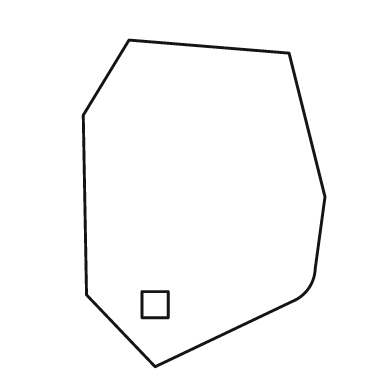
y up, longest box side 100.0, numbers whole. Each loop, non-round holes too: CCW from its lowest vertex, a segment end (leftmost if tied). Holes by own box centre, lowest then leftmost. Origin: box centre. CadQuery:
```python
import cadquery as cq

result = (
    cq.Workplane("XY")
    .moveTo(-15.0, -50.0)
    .lineTo(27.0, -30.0)
    .threePointArc((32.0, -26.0), (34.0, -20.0))
    .lineTo(37.0, 2.0)
    .lineTo(26.0, 46.0)
    .lineTo(-23.0, 50.0)
    .lineTo(-37.0, 27.0)
    .lineTo(-36.0, -28.0)
    .close()
    .moveTo(-19.0, -35.0)
    .lineTo(-11.0, -35.0)
    .lineTo(-11.0, -27.0)
    .lineTo(-19.0, -27.0)
    .close()
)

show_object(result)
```